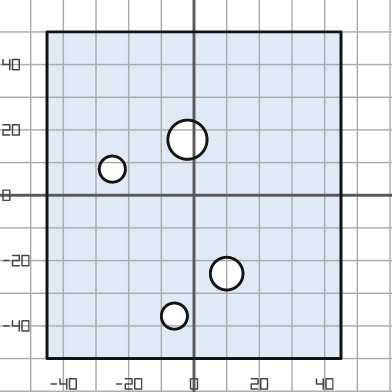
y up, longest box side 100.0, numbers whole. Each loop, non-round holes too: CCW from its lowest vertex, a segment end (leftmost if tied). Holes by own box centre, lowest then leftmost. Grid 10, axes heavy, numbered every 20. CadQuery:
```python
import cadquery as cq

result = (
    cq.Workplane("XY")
    .moveTo(-45.0, -50.0)
    .lineTo(45.0, -50.0)
    .lineTo(45.0, 50.0)
    .lineTo(-45.0, 50.0)
    .close()
    .moveTo(-6.0, -37.0)
    .circle(4.0)
    .moveTo(10.0, -24.0)
    .circle(5.0)
    .moveTo(-25.0, 8.0)
    .circle(4.0)
    .moveTo(-2.0, 17.0)
    .circle(6.0)
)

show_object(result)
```